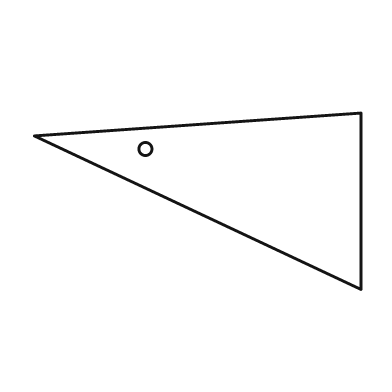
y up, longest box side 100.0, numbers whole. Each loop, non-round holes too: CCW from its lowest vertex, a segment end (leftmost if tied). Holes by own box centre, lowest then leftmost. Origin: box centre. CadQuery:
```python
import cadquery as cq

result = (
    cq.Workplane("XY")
    .moveTo(50.0, -27.0)
    .lineTo(50.0, 27.0)
    .lineTo(-50.0, 20.0)
    .close()
    .moveTo(-16.0, 16.0)
    .circle(2.0)
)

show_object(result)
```